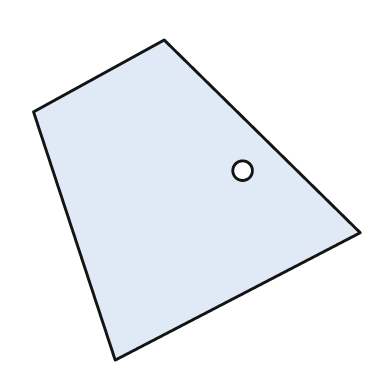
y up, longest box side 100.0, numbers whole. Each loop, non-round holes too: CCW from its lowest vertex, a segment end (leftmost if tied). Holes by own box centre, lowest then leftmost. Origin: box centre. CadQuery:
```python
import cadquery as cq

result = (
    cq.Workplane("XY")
    .moveTo(-25.0, -49.0)
    .lineTo(50.0, -10.0)
    .lineTo(-10.0, 49.0)
    .lineTo(-50.0, 27.0)
    .close()
    .moveTo(14.0, 9.0)
    .circle(3.0)
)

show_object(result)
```